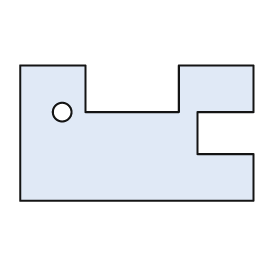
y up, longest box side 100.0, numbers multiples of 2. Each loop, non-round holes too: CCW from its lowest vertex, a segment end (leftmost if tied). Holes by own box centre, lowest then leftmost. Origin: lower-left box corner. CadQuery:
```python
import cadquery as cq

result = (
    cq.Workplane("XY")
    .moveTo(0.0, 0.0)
    .lineTo(100.0, 0.0)
    .lineTo(100.0, 20.0)
    .lineTo(76.0, 20.0)
    .lineTo(76.0, 38.0)
    .lineTo(100.0, 38.0)
    .lineTo(100.0, 58.0)
    .lineTo(68.0, 58.0)
    .lineTo(68.0, 38.0)
    .lineTo(28.0, 38.0)
    .lineTo(28.0, 58.0)
    .lineTo(0.0, 58.0)
    .close()
    .moveTo(18.0, 38.0)
    .circle(4.0)
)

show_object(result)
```